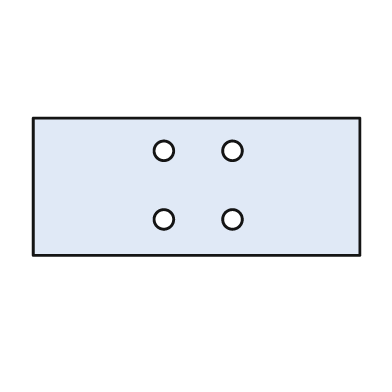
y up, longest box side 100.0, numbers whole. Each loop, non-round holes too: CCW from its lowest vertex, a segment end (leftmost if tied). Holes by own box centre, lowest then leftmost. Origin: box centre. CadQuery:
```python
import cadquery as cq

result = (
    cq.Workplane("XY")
    .moveTo(-50.0, -21.0)
    .lineTo(50.0, -21.0)
    .lineTo(50.0, 21.0)
    .lineTo(-50.0, 21.0)
    .close()
    .moveTo(-10.0, -10.0)
    .circle(3.0)
    .moveTo(11.0, -10.0)
    .circle(3.0)
    .moveTo(-10.0, 11.0)
    .circle(3.0)
    .moveTo(11.0, 11.0)
    .circle(3.0)
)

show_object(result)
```